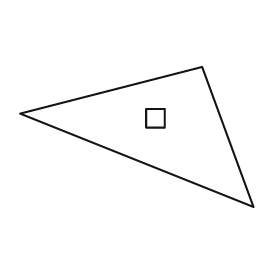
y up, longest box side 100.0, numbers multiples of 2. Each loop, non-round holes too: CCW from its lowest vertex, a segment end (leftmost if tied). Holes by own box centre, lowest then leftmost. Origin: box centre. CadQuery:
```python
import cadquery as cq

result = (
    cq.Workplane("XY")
    .moveTo(50.0, -30.0)
    .lineTo(28.0, 30.0)
    .lineTo(-50.0, 10.0)
    .close()
    .moveTo(4.0, 4.0)
    .lineTo(12.0, 4.0)
    .lineTo(12.0, 12.0)
    .lineTo(4.0, 12.0)
    .close()
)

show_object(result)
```